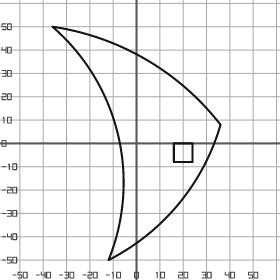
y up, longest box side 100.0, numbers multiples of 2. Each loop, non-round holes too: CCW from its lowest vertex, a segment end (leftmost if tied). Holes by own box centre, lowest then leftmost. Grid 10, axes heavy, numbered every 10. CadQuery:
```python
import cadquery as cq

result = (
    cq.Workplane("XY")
    .moveTo(-12.0, -50.0)
    .threePointArc((18.0, -26.0), (36.0, 8.0))
    .threePointArc((4.0, 36.0), (-36.0, 50.0))
    .threePointArc((-8.0, 4.0), (-12.0, -50.0))
    .close()
    .moveTo(16.0, -8.0)
    .lineTo(24.0, -8.0)
    .lineTo(24.0, 0.0)
    .lineTo(16.0, 0.0)
    .close()
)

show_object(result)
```